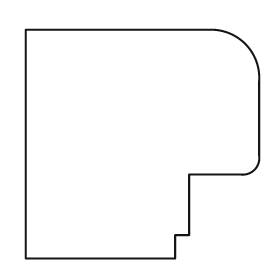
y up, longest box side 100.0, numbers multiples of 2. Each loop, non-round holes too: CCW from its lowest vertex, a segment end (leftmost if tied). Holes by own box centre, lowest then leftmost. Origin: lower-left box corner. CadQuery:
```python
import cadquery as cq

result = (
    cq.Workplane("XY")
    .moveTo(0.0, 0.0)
    .lineTo(64.0, 0.0)
    .lineTo(64.0, 10.0)
    .lineTo(70.0, 10.0)
    .lineTo(70.0, 36.0)
    .lineTo(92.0, 36.0)
    .threePointArc((98.0, 38.0), (100.0, 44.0))
    .lineTo(100.0, 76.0)
    .threePointArc((94.0, 92.0), (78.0, 98.0))
    .lineTo(0.0, 98.0)
    .close()
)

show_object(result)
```